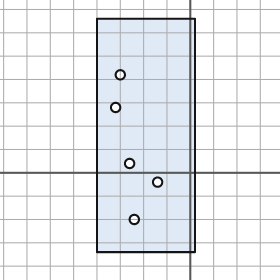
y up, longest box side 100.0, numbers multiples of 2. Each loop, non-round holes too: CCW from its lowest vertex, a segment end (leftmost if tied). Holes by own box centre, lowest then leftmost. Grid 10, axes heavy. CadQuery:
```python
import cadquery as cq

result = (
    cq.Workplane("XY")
    .moveTo(-40.0, -34.0)
    .lineTo(2.0, -34.0)
    .lineTo(2.0, 66.0)
    .lineTo(-40.0, 66.0)
    .close()
    .moveTo(-24.0, -20.0)
    .circle(2.0)
    .moveTo(-14.0, -4.0)
    .circle(2.0)
    .moveTo(-26.0, 4.0)
    .circle(2.0)
    .moveTo(-32.0, 28.0)
    .circle(2.0)
    .moveTo(-30.0, 42.0)
    .circle(2.0)
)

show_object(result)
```